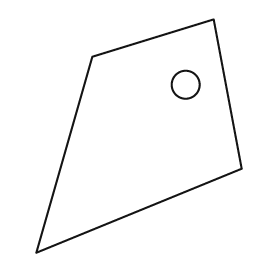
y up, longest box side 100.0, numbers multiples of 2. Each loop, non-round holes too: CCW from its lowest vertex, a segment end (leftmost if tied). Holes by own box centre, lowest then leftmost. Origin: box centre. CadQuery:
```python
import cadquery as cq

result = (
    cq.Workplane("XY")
    .moveTo(-44.0, -50.0)
    .lineTo(44.0, -14.0)
    .lineTo(32.0, 50.0)
    .lineTo(-20.0, 34.0)
    .close()
    .moveTo(20.0, 22.0)
    .circle(6.0)
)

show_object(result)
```